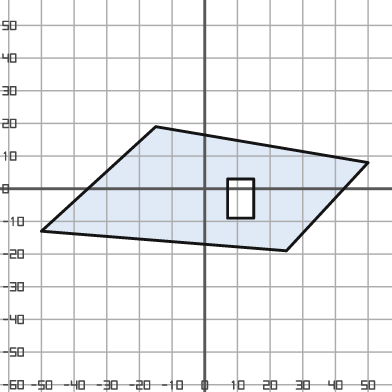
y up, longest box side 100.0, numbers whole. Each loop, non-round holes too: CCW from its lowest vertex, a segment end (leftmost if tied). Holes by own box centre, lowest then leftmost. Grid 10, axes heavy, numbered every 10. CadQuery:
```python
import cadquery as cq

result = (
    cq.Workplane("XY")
    .moveTo(25.0, -19.0)
    .lineTo(50.0, 8.0)
    .lineTo(-15.0, 19.0)
    .lineTo(-50.0, -13.0)
    .close()
    .moveTo(7.0, -9.0)
    .lineTo(15.0, -9.0)
    .lineTo(15.0, 3.0)
    .lineTo(7.0, 3.0)
    .close()
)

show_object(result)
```